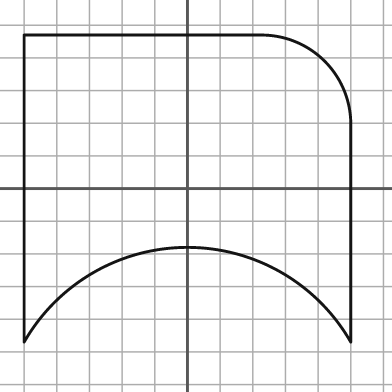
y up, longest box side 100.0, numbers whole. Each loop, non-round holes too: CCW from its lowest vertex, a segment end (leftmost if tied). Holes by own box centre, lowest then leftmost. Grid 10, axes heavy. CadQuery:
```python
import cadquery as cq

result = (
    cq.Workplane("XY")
    .moveTo(-50.0, -47.0)
    .threePointArc((0.0, -18.0), (50.0, -47.0))
    .lineTo(50.0, 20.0)
    .threePointArc((42.0, 39.0), (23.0, 47.0))
    .lineTo(-50.0, 47.0)
    .close()
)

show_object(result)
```